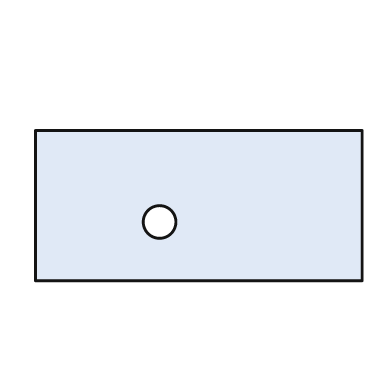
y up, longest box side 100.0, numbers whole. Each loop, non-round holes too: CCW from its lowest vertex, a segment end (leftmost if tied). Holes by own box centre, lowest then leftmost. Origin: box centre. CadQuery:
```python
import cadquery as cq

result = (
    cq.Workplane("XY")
    .moveTo(-50.0, -23.0)
    .lineTo(50.0, -23.0)
    .lineTo(50.0, 23.0)
    .lineTo(-50.0, 23.0)
    .close()
    .moveTo(-12.0, -5.0)
    .circle(5.0)
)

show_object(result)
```